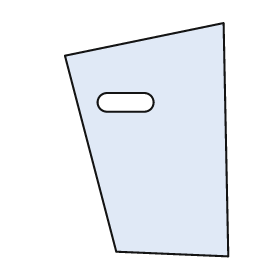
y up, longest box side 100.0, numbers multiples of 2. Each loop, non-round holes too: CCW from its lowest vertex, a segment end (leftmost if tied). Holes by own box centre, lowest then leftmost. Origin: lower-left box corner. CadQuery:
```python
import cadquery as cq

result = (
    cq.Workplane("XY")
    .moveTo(70.0, 0.0)
    .lineTo(68.0, 100.0)
    .lineTo(0.0, 86.0)
    .lineTo(22.0, 2.0)
    .close()
    .moveTo(18.0, 62.0)
    .lineTo(34.0, 62.0)
    .threePointArc((38.0, 66.0), (34.0, 70.0))
    .lineTo(18.0, 70.0)
    .threePointArc((14.0, 66.0), (18.0, 62.0))
    .close()
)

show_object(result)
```